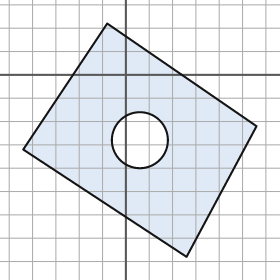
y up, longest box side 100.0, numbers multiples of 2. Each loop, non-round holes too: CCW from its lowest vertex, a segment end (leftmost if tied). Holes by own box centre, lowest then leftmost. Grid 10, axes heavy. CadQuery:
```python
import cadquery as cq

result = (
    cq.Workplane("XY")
    .moveTo(26.0, -78.0)
    .lineTo(56.0, -22.0)
    .lineTo(-8.0, 22.0)
    .lineTo(-44.0, -32.0)
    .close()
    .moveTo(6.0, -28.0)
    .circle(12.0)
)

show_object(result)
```